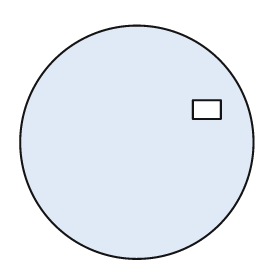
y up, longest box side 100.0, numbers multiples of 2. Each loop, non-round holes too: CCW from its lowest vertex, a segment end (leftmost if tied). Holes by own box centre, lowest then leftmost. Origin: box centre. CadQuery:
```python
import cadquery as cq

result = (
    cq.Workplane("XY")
    .moveTo(0.0, 0.0)
    .circle(50.0)
    .moveTo(24.0, 10.0)
    .lineTo(36.0, 10.0)
    .lineTo(36.0, 18.0)
    .lineTo(24.0, 18.0)
    .close()
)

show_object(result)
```